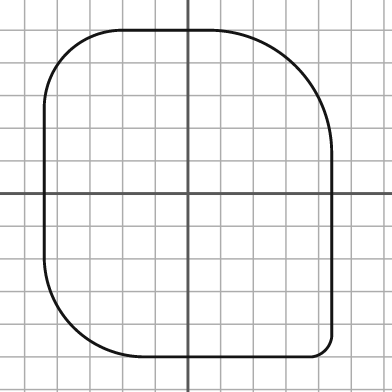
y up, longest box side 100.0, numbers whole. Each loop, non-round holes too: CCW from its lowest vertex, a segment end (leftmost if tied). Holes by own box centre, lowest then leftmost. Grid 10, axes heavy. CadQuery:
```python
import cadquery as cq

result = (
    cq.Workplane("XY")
    .moveTo(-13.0, -50.0)
    .lineTo(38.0, -50.0)
    .threePointArc((42.0, -48.0), (44.0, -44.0))
    .lineTo(44.0, 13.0)
    .threePointArc((33.0, 39.0), (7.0, 50.0))
    .lineTo(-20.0, 50.0)
    .threePointArc((-37.0, 43.0), (-44.0, 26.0))
    .lineTo(-44.0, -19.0)
    .threePointArc((-35.0, -41.0), (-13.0, -50.0))
    .close()
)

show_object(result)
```